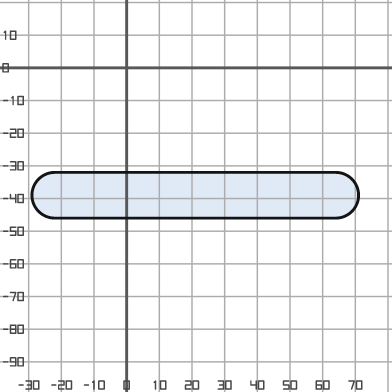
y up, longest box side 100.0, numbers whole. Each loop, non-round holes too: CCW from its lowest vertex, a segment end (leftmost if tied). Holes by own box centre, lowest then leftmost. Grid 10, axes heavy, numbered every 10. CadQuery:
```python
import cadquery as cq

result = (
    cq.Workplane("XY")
    .moveTo(-22.0, -46.0)
    .lineTo(64.0, -46.0)
    .threePointArc((71.0, -39.0), (64.0, -32.0))
    .lineTo(-22.0, -32.0)
    .threePointArc((-29.0, -39.0), (-22.0, -46.0))
    .close()
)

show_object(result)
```